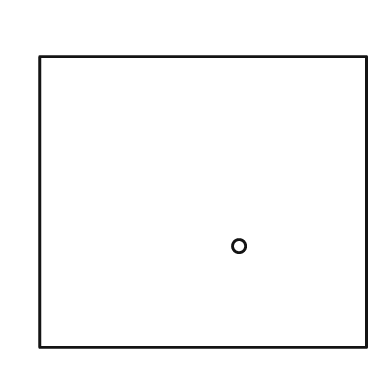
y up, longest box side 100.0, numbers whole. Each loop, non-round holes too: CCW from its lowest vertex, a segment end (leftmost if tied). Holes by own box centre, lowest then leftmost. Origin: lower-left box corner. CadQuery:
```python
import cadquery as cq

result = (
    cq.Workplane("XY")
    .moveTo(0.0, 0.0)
    .lineTo(100.0, 0.0)
    .lineTo(100.0, 89.0)
    .lineTo(0.0, 89.0)
    .close()
    .moveTo(61.0, 31.0)
    .circle(2.0)
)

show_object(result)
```